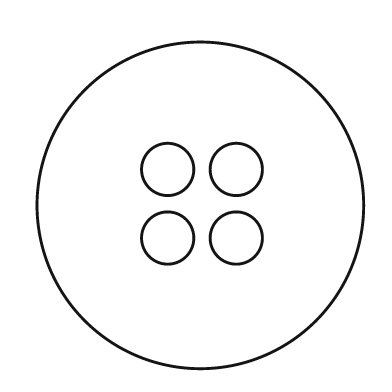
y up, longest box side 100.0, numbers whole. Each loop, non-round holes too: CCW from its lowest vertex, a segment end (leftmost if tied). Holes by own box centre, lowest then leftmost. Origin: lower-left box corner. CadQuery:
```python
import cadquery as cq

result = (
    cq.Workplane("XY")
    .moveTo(50.0, 50.0)
    .circle(50.0)
    .moveTo(40.0, 40.0)
    .circle(8.0)
    .moveTo(61.0, 40.0)
    .circle(8.0)
    .moveTo(40.0, 61.0)
    .circle(8.0)
    .moveTo(61.0, 61.0)
    .circle(8.0)
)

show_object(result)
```